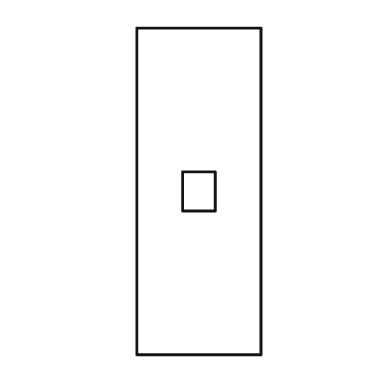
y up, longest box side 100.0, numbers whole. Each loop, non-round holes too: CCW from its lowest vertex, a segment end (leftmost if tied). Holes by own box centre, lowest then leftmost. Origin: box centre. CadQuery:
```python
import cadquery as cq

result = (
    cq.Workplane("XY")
    .moveTo(-19.0, -50.0)
    .lineTo(19.0, -50.0)
    .lineTo(19.0, 50.0)
    .lineTo(-19.0, 50.0)
    .close()
    .moveTo(-5.0, -6.0)
    .lineTo(5.0, -6.0)
    .lineTo(5.0, 6.0)
    .lineTo(-5.0, 6.0)
    .close()
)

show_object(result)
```